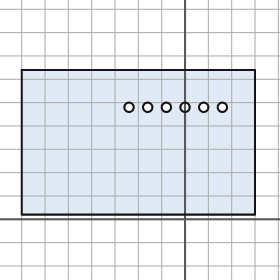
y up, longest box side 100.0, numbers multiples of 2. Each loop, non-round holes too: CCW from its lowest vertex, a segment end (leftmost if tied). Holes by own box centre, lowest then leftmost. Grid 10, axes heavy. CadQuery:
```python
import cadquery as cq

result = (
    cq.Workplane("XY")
    .moveTo(-70.0, 2.0)
    .lineTo(30.0, 2.0)
    .lineTo(30.0, 64.0)
    .lineTo(-70.0, 64.0)
    .close()
    .moveTo(-24.0, 48.0)
    .circle(2.0)
    .moveTo(-16.0, 48.0)
    .circle(2.0)
    .moveTo(-8.0, 48.0)
    .circle(2.0)
    .moveTo(0.0, 48.0)
    .circle(2.0)
    .moveTo(8.0, 48.0)
    .circle(2.0)
    .moveTo(16.0, 48.0)
    .circle(2.0)
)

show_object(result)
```